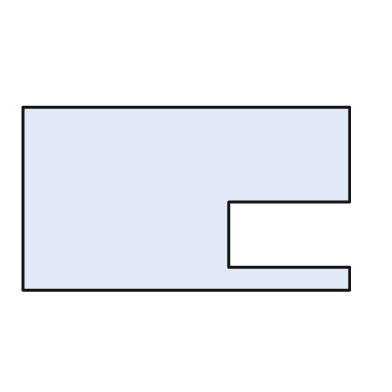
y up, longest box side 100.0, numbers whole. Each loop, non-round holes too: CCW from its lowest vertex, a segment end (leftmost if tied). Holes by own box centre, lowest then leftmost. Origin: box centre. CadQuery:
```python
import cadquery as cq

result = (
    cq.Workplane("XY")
    .moveTo(-50.0, -28.0)
    .lineTo(50.0, -28.0)
    .lineTo(50.0, -21.0)
    .lineTo(13.0, -21.0)
    .lineTo(13.0, -1.0)
    .lineTo(50.0, -1.0)
    .lineTo(50.0, 28.0)
    .lineTo(-50.0, 28.0)
    .close()
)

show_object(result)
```